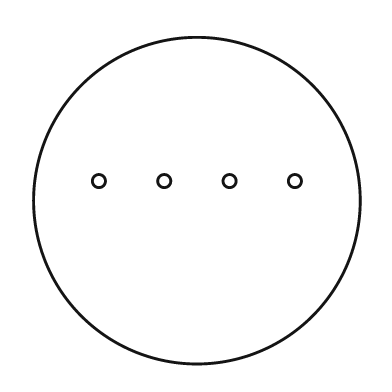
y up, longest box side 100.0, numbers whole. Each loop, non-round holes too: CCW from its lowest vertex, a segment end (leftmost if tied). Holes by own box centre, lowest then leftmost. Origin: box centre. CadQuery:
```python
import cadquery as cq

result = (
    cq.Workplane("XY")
    .moveTo(0.0, 0.0)
    .circle(50.0)
    .moveTo(-30.0, 6.0)
    .circle(2.0)
    .moveTo(-10.0, 6.0)
    .circle(2.0)
    .moveTo(10.0, 6.0)
    .circle(2.0)
    .moveTo(30.0, 6.0)
    .circle(2.0)
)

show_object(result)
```